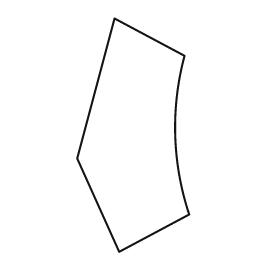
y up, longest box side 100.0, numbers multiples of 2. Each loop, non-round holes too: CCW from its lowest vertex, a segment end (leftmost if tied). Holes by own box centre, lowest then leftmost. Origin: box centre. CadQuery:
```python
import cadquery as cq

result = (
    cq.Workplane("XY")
    .moveTo(-6.0, -50.0)
    .lineTo(24.0, -34.0)
    .threePointArc((18.0, 0.0), (22.0, 34.0))
    .lineTo(-8.0, 50.0)
    .lineTo(-24.0, -10.0)
    .close()
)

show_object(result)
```